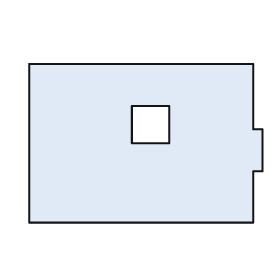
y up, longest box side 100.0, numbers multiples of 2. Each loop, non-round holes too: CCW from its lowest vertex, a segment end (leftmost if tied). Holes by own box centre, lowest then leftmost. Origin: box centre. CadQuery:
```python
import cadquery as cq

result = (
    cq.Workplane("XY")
    .moveTo(-50.0, -34.0)
    .lineTo(46.0, -34.0)
    .lineTo(46.0, -12.0)
    .lineTo(50.0, -12.0)
    .lineTo(50.0, 6.0)
    .lineTo(46.0, 6.0)
    .lineTo(46.0, 34.0)
    .lineTo(-50.0, 34.0)
    .close()
    .moveTo(-6.0, 0.0)
    .lineTo(10.0, 0.0)
    .lineTo(10.0, 16.0)
    .lineTo(-6.0, 16.0)
    .close()
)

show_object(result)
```